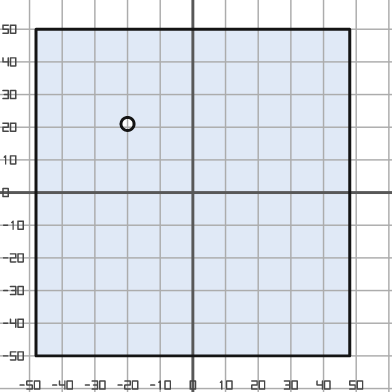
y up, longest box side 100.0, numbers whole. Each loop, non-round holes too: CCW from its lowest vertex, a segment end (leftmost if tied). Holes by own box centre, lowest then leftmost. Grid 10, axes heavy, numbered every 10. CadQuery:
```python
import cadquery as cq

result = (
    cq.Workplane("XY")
    .moveTo(-48.0, -50.0)
    .lineTo(48.0, -50.0)
    .lineTo(48.0, 50.0)
    .lineTo(-48.0, 50.0)
    .close()
    .moveTo(-20.0, 21.0)
    .circle(2.0)
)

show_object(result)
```